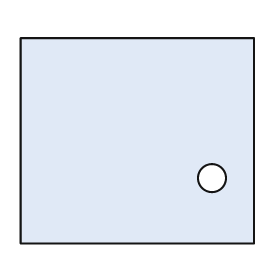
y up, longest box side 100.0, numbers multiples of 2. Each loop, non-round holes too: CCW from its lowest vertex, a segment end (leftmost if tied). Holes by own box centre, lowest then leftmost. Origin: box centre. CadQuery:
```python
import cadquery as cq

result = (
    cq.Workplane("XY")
    .moveTo(-50.0, -44.0)
    .lineTo(50.0, -44.0)
    .lineTo(50.0, 44.0)
    .lineTo(-50.0, 44.0)
    .close()
    .moveTo(32.0, -16.0)
    .circle(6.0)
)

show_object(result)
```